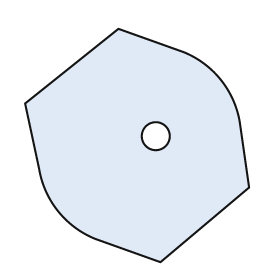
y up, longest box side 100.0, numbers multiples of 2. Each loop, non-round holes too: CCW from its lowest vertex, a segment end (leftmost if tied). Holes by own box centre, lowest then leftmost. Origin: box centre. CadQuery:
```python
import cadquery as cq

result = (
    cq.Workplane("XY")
    .moveTo(10.0, -50.0)
    .lineTo(48.0, -18.0)
    .lineTo(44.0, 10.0)
    .threePointArc((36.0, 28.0), (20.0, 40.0))
    .lineTo(-8.0, 50.0)
    .lineTo(-48.0, 18.0)
    .lineTo(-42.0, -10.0)
    .threePointArc((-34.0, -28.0), (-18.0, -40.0))
    .close()
    .moveTo(8.0, 4.0)
    .circle(6.0)
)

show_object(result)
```